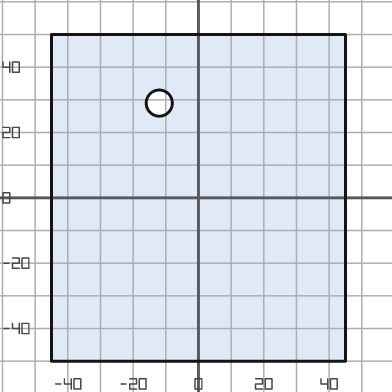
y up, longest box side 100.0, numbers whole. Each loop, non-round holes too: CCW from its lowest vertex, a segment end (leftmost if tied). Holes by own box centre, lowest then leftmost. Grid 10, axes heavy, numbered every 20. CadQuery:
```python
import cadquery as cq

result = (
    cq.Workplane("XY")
    .moveTo(-45.0, -50.0)
    .lineTo(45.0, -50.0)
    .lineTo(45.0, 50.0)
    .lineTo(-45.0, 50.0)
    .close()
    .moveTo(-12.0, 29.0)
    .circle(4.0)
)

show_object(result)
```